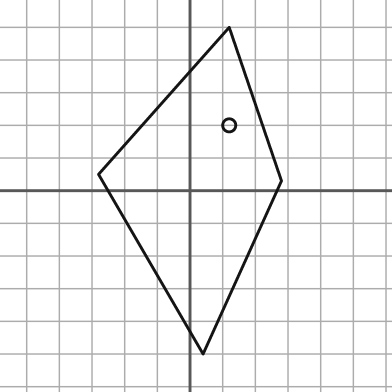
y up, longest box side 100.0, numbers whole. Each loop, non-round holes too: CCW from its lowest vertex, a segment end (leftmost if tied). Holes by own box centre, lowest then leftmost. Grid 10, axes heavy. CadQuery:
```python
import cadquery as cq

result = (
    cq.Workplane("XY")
    .moveTo(4.0, -50.0)
    .lineTo(28.0, 3.0)
    .lineTo(12.0, 50.0)
    .lineTo(-28.0, 5.0)
    .close()
    .moveTo(12.0, 20.0)
    .circle(2.0)
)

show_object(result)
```